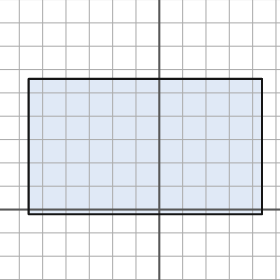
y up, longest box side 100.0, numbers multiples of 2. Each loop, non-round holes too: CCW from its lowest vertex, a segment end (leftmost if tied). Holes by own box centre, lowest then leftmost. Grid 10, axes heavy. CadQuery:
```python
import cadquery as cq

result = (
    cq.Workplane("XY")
    .moveTo(-56.0, -2.0)
    .lineTo(44.0, -2.0)
    .lineTo(44.0, 56.0)
    .lineTo(-56.0, 56.0)
    .close()
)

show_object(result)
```